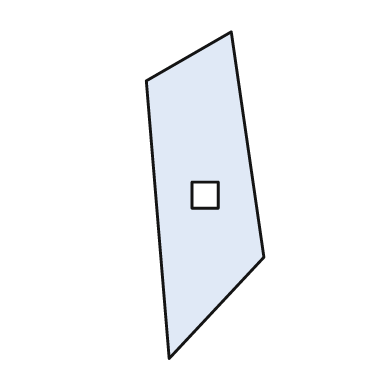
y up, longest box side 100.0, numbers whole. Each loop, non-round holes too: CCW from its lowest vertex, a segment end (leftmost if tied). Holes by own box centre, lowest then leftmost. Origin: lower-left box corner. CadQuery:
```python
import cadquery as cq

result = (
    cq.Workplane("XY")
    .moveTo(7.0, 0.0)
    .lineTo(36.0, 31.0)
    .lineTo(26.0, 100.0)
    .lineTo(0.0, 85.0)
    .close()
    .moveTo(14.0, 46.0)
    .lineTo(22.0, 46.0)
    .lineTo(22.0, 54.0)
    .lineTo(14.0, 54.0)
    .close()
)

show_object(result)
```